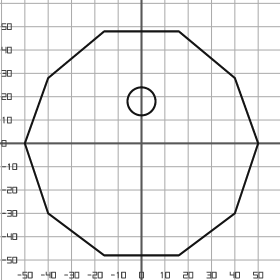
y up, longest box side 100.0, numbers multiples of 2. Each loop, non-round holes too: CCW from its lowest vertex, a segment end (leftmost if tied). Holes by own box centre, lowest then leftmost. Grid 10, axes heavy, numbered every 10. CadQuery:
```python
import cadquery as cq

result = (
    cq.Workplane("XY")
    .moveTo(-16.0, -48.0)
    .lineTo(16.0, -48.0)
    .lineTo(40.0, -30.0)
    .lineTo(50.0, 0.0)
    .lineTo(40.0, 28.0)
    .lineTo(16.0, 48.0)
    .lineTo(-16.0, 48.0)
    .lineTo(-40.0, 28.0)
    .lineTo(-50.0, 0.0)
    .lineTo(-40.0, -30.0)
    .close()
    .moveTo(0.0, 18.0)
    .circle(6.0)
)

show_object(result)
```